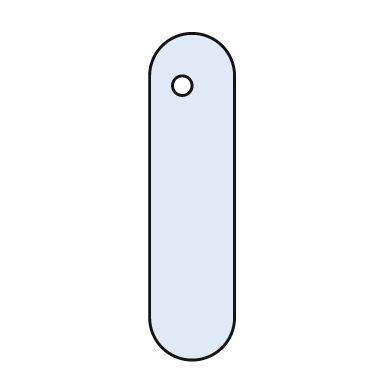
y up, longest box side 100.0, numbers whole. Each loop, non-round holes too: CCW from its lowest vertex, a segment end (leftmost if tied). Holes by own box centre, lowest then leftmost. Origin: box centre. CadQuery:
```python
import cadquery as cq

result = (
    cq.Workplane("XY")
    .moveTo(-13.0, -37.0)
    .threePointArc((0.0, -50.0), (13.0, -37.0))
    .lineTo(13.0, 37.0)
    .threePointArc((0.0, 50.0), (-13.0, 37.0))
    .close()
    .moveTo(-3.0, 34.0)
    .circle(3.0)
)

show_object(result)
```